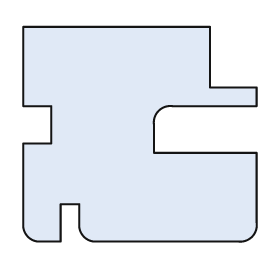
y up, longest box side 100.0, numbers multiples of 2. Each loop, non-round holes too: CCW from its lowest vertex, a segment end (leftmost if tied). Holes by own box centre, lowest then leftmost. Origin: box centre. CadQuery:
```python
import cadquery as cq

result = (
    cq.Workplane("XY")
    .moveTo(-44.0, -46.0)
    .lineTo(-34.0, -46.0)
    .lineTo(-34.0, -30.0)
    .lineTo(-26.0, -30.0)
    .lineTo(-26.0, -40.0)
    .threePointArc((-24.0, -44.0), (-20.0, -46.0))
    .lineTo(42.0, -46.0)
    .threePointArc((48.0, -44.0), (50.0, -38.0))
    .lineTo(50.0, -8.0)
    .lineTo(6.0, -8.0)
    .lineTo(6.0, 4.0)
    .threePointArc((8.0, 10.0), (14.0, 12.0))
    .lineTo(50.0, 12.0)
    .lineTo(50.0, 20.0)
    .lineTo(30.0, 20.0)
    .lineTo(30.0, 46.0)
    .lineTo(-50.0, 46.0)
    .lineTo(-50.0, 12.0)
    .lineTo(-38.0, 12.0)
    .lineTo(-38.0, -4.0)
    .lineTo(-50.0, -4.0)
    .lineTo(-50.0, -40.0)
    .threePointArc((-48.0, -44.0), (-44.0, -46.0))
    .close()
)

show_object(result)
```